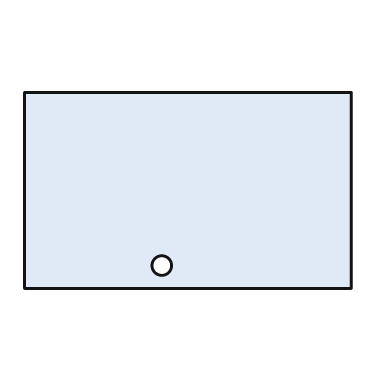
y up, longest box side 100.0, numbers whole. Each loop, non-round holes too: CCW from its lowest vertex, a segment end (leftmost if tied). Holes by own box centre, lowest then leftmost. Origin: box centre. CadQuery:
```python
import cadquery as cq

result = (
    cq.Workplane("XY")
    .moveTo(-50.0, -30.0)
    .lineTo(50.0, -30.0)
    .lineTo(50.0, 30.0)
    .lineTo(-50.0, 30.0)
    .close()
    .moveTo(-8.0, -23.0)
    .circle(3.0)
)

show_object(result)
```